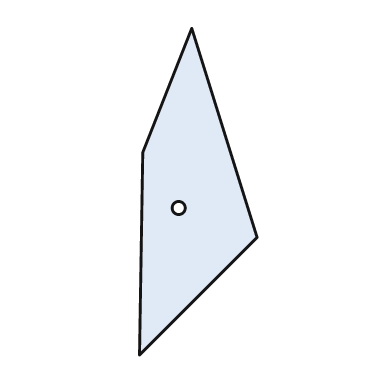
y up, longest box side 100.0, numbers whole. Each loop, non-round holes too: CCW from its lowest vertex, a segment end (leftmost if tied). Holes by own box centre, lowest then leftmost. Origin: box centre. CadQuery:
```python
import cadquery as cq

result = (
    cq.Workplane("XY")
    .moveTo(-18.0, -50.0)
    .lineTo(18.0, -14.0)
    .lineTo(-2.0, 50.0)
    .lineTo(-17.0, 12.0)
    .close()
    .moveTo(-6.0, -5.0)
    .circle(2.0)
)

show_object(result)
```